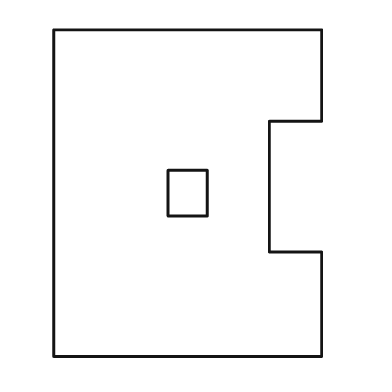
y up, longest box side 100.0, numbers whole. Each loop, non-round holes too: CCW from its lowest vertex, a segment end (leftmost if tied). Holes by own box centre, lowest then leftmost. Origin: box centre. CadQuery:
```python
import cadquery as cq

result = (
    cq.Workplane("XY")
    .moveTo(-41.0, -50.0)
    .lineTo(41.0, -50.0)
    .lineTo(41.0, -18.0)
    .lineTo(25.0, -18.0)
    .lineTo(25.0, 22.0)
    .lineTo(41.0, 22.0)
    .lineTo(41.0, 50.0)
    .lineTo(-41.0, 50.0)
    .close()
    .moveTo(-6.0, -7.0)
    .lineTo(6.0, -7.0)
    .lineTo(6.0, 7.0)
    .lineTo(-6.0, 7.0)
    .close()
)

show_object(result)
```